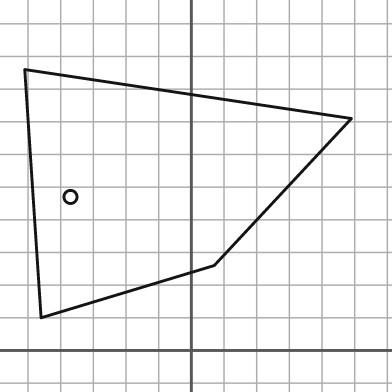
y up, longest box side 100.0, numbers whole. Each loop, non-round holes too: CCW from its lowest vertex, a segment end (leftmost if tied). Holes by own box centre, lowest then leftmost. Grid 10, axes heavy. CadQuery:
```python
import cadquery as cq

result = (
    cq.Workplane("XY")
    .moveTo(-46.0, 10.0)
    .lineTo(7.0, 26.0)
    .lineTo(49.0, 71.0)
    .lineTo(-51.0, 86.0)
    .close()
    .moveTo(-37.0, 47.0)
    .circle(2.0)
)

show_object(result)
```